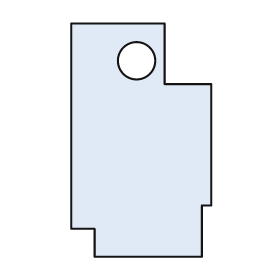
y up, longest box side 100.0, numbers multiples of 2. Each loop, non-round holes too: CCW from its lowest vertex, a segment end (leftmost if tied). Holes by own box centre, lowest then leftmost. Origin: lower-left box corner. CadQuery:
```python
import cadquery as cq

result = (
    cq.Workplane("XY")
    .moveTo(10.0, 0.0)
    .lineTo(56.0, 0.0)
    .lineTo(56.0, 22.0)
    .lineTo(60.0, 22.0)
    .lineTo(60.0, 74.0)
    .lineTo(40.0, 74.0)
    .lineTo(40.0, 100.0)
    .lineTo(0.0, 100.0)
    .lineTo(0.0, 12.0)
    .lineTo(10.0, 12.0)
    .close()
    .moveTo(28.0, 84.0)
    .circle(8.0)
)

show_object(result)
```